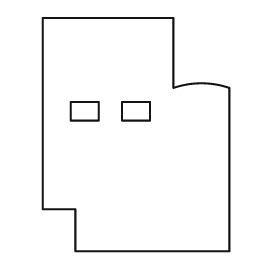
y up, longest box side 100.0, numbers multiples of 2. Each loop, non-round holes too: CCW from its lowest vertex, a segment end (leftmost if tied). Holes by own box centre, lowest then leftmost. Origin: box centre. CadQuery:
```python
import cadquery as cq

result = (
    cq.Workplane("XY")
    .moveTo(-26.0, -50.0)
    .lineTo(40.0, -50.0)
    .lineTo(40.0, 20.0)
    .threePointArc((28.0, 22.0), (16.0, 20.0))
    .lineTo(16.0, 50.0)
    .lineTo(-40.0, 50.0)
    .lineTo(-40.0, -32.0)
    .lineTo(-26.0, -32.0)
    .close()
    .moveTo(-28.0, 6.0)
    .lineTo(-16.0, 6.0)
    .lineTo(-16.0, 14.0)
    .lineTo(-28.0, 14.0)
    .close()
    .moveTo(-6.0, 6.0)
    .lineTo(6.0, 6.0)
    .lineTo(6.0, 14.0)
    .lineTo(-6.0, 14.0)
    .close()
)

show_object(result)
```